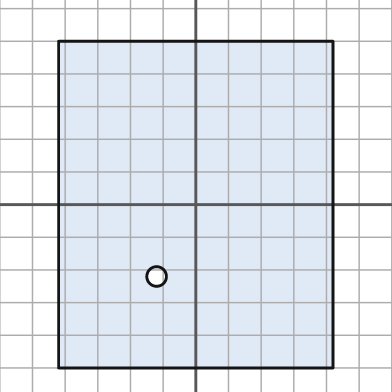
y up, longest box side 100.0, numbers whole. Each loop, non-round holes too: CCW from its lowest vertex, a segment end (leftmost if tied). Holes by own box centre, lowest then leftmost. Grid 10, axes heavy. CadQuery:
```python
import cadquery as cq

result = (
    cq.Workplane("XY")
    .moveTo(-42.0, -50.0)
    .lineTo(42.0, -50.0)
    .lineTo(42.0, 50.0)
    .lineTo(-42.0, 50.0)
    .close()
    .moveTo(-12.0, -22.0)
    .circle(3.0)
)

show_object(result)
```